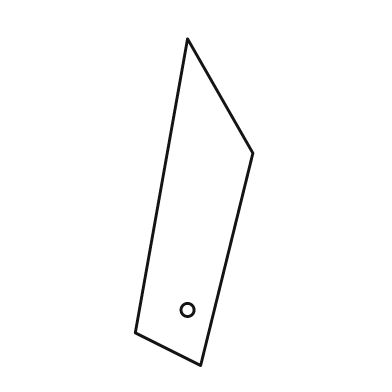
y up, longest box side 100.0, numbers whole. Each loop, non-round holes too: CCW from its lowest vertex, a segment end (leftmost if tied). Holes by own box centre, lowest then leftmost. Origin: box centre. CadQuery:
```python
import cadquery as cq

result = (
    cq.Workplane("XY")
    .moveTo(2.0, -50.0)
    .lineTo(18.0, 15.0)
    .lineTo(-2.0, 50.0)
    .lineTo(-18.0, -40.0)
    .close()
    .moveTo(-2.0, -33.0)
    .circle(2.0)
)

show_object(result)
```